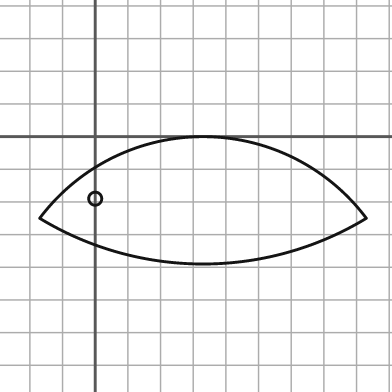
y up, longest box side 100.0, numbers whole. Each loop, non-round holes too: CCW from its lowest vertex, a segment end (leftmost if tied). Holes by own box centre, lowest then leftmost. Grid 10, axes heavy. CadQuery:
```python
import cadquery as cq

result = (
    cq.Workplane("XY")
    .moveTo(-17.0, -25.0)
    .threePointArc((33.0, -39.0), (83.0, -25.0))
    .threePointArc((33.0, 0.0), (-17.0, -25.0))
    .close()
    .moveTo(0.0, -19.0)
    .circle(2.0)
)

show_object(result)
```